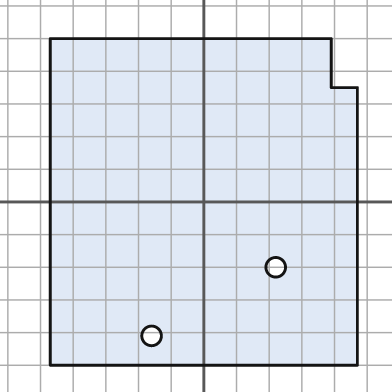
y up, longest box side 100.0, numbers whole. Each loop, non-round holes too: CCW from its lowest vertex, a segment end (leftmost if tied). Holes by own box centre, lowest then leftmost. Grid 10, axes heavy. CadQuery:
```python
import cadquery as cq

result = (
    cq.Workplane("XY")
    .moveTo(-47.0, -50.0)
    .lineTo(47.0, -50.0)
    .lineTo(47.0, 35.0)
    .lineTo(39.0, 35.0)
    .lineTo(39.0, 50.0)
    .lineTo(-47.0, 50.0)
    .close()
    .moveTo(-16.0, -41.0)
    .circle(3.0)
    .moveTo(22.0, -20.0)
    .circle(3.0)
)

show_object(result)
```